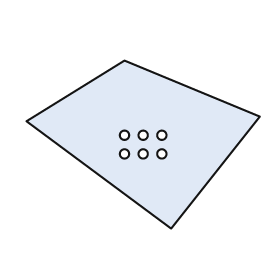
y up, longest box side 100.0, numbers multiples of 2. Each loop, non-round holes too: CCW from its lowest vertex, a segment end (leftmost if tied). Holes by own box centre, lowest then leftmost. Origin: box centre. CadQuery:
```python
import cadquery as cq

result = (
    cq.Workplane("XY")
    .moveTo(12.0, -36.0)
    .lineTo(50.0, 12.0)
    .lineTo(-8.0, 36.0)
    .lineTo(-50.0, 10.0)
    .close()
    .moveTo(-8.0, -4.0)
    .circle(2.0)
    .moveTo(0.0, -4.0)
    .circle(2.0)
    .moveTo(8.0, -4.0)
    .circle(2.0)
    .moveTo(-8.0, 4.0)
    .circle(2.0)
    .moveTo(0.0, 4.0)
    .circle(2.0)
    .moveTo(8.0, 4.0)
    .circle(2.0)
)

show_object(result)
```